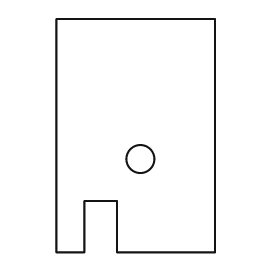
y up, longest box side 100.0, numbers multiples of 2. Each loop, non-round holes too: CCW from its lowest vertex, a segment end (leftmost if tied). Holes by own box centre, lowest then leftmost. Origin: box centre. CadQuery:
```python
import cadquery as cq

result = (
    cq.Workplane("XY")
    .moveTo(-34.0, -50.0)
    .lineTo(-22.0, -50.0)
    .lineTo(-22.0, -28.0)
    .lineTo(-8.0, -28.0)
    .lineTo(-8.0, -50.0)
    .lineTo(34.0, -50.0)
    .lineTo(34.0, 50.0)
    .lineTo(-34.0, 50.0)
    .close()
    .moveTo(2.0, -10.0)
    .circle(6.0)
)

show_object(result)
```